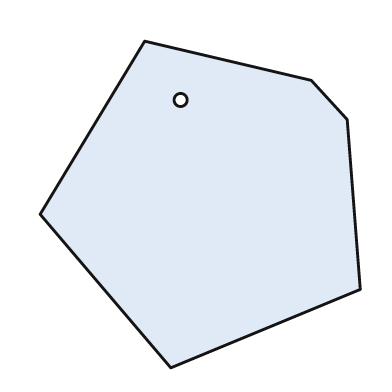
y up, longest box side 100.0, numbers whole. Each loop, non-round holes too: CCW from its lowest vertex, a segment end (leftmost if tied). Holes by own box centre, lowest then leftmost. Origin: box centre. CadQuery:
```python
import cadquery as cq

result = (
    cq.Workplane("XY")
    .moveTo(-9.0, -50.0)
    .lineTo(49.0, -26.0)
    .lineTo(45.0, 26.0)
    .lineTo(34.0, 38.0)
    .lineTo(-17.0, 50.0)
    .lineTo(-49.0, -3.0)
    .close()
    .moveTo(-6.0, 32.0)
    .circle(2.0)
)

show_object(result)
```